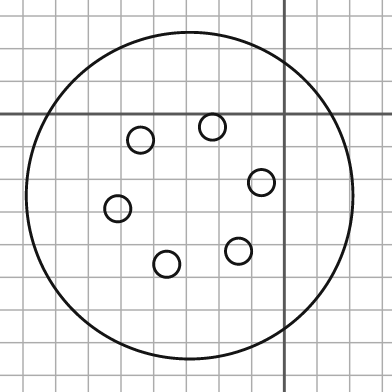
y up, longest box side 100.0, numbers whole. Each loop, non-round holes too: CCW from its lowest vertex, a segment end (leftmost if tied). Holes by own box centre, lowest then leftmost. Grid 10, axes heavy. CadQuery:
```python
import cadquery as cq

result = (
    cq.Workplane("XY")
    .moveTo(-29.0, -25.0)
    .circle(50.0)
    .moveTo(-36.0, -46.0)
    .circle(4.0)
    .moveTo(-14.0, -42.0)
    .circle(4.0)
    .moveTo(-51.0, -29.0)
    .circle(4.0)
    .moveTo(-7.0, -21.0)
    .circle(4.0)
    .moveTo(-44.0, -8.0)
    .circle(4.0)
    .moveTo(-22.0, -4.0)
    .circle(4.0)
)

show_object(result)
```